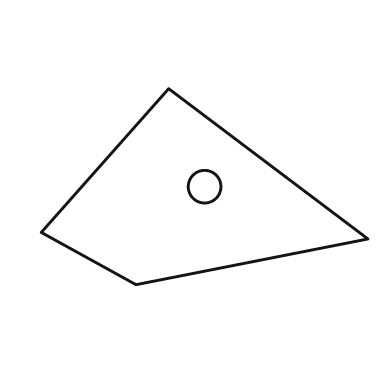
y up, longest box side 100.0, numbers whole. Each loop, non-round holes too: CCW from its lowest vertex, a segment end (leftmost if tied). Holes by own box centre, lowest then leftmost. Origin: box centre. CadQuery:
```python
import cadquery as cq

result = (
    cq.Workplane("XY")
    .moveTo(-21.0, -30.0)
    .lineTo(50.0, -16.0)
    .lineTo(-11.0, 30.0)
    .lineTo(-50.0, -14.0)
    .close()
    .moveTo(0.0, 0.0)
    .circle(5.0)
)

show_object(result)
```